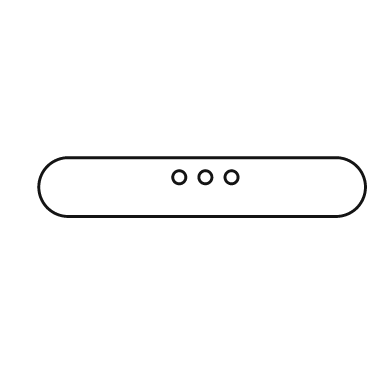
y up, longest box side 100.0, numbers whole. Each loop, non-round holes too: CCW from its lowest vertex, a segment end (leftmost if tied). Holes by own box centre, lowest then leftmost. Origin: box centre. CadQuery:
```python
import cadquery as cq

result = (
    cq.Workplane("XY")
    .moveTo(-41.0, -9.0)
    .lineTo(41.0, -9.0)
    .threePointArc((50.0, 0.0), (41.0, 9.0))
    .lineTo(-41.0, 9.0)
    .threePointArc((-50.0, 0.0), (-41.0, -9.0))
    .close()
    .moveTo(-7.0, 3.0)
    .circle(2.0)
    .moveTo(1.0, 3.0)
    .circle(2.0)
    .moveTo(9.0, 3.0)
    .circle(2.0)
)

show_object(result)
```